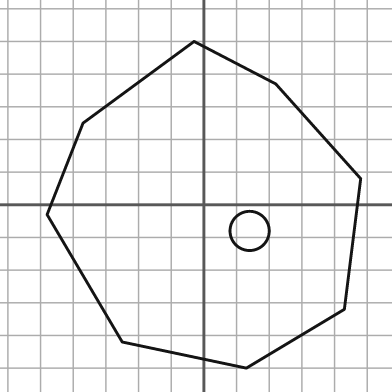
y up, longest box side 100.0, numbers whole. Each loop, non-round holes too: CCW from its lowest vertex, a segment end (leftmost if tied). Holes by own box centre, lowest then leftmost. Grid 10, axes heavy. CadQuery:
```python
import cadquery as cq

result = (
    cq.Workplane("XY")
    .moveTo(13.0, -50.0)
    .lineTo(43.0, -32.0)
    .lineTo(48.0, 8.0)
    .lineTo(22.0, 37.0)
    .lineTo(-3.0, 50.0)
    .lineTo(-37.0, 25.0)
    .lineTo(-48.0, -3.0)
    .lineTo(-25.0, -42.0)
    .close()
    .moveTo(14.0, -8.0)
    .circle(6.0)
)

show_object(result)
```